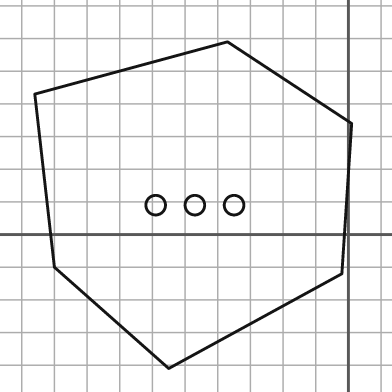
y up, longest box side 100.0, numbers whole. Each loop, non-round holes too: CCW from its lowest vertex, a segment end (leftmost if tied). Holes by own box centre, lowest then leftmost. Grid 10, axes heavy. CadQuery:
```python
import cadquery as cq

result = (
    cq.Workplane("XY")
    .moveTo(-55.0, -41.0)
    .lineTo(-2.0, -12.0)
    .lineTo(1.0, 34.0)
    .lineTo(-37.0, 59.0)
    .lineTo(-96.0, 43.0)
    .lineTo(-90.0, -10.0)
    .close()
    .moveTo(-59.0, 9.0)
    .circle(3.0)
    .moveTo(-47.0, 9.0)
    .circle(3.0)
    .moveTo(-35.0, 9.0)
    .circle(3.0)
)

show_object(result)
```